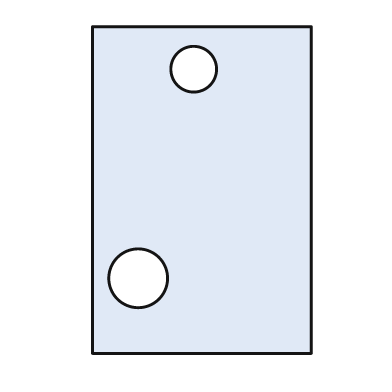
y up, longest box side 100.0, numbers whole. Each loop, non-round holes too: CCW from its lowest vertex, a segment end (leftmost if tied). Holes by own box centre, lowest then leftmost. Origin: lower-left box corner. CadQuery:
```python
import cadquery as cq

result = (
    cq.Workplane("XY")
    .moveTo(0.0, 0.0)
    .lineTo(67.0, 0.0)
    .lineTo(67.0, 100.0)
    .lineTo(0.0, 100.0)
    .close()
    .moveTo(14.0, 23.0)
    .circle(9.0)
    .moveTo(31.0, 87.0)
    .circle(7.0)
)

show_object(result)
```